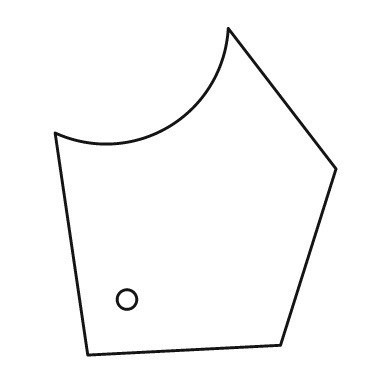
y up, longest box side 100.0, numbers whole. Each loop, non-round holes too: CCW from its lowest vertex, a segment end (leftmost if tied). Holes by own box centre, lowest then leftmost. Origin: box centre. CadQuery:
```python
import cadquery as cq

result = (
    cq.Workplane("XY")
    .moveTo(-33.0, -50.0)
    .lineTo(26.0, -47.0)
    .lineTo(43.0, 7.0)
    .lineTo(10.0, 50.0)
    .threePointArc((-8.0, 20.0), (-43.0, 18.0))
    .close()
    .moveTo(-21.0, -33.0)
    .circle(3.0)
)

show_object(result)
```